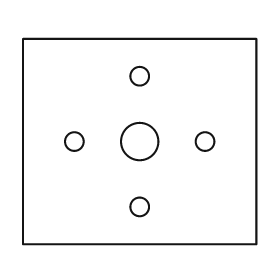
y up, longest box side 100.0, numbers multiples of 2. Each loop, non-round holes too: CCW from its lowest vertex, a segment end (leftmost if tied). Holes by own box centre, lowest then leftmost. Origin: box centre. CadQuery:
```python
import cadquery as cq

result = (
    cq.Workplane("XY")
    .moveTo(-50.0, -44.0)
    .lineTo(50.0, -44.0)
    .lineTo(50.0, 44.0)
    .lineTo(-50.0, 44.0)
    .close()
    .moveTo(0.0, -28.0)
    .circle(4.0)
    .moveTo(-28.0, 0.0)
    .circle(4.0)
    .moveTo(0.0, 0.0)
    .circle(8.0)
    .moveTo(28.0, 0.0)
    .circle(4.0)
    .moveTo(0.0, 28.0)
    .circle(4.0)
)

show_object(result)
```